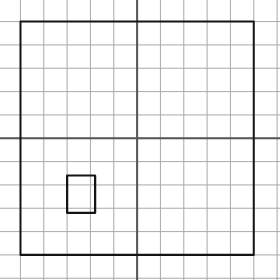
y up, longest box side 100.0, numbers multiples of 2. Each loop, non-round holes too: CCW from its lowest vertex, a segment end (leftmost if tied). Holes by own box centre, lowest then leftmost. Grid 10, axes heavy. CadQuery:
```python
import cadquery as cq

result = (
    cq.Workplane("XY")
    .moveTo(-50.0, -50.0)
    .lineTo(50.0, -50.0)
    .lineTo(50.0, 50.0)
    .lineTo(-50.0, 50.0)
    .close()
    .moveTo(-30.0, -32.0)
    .lineTo(-18.0, -32.0)
    .lineTo(-18.0, -16.0)
    .lineTo(-30.0, -16.0)
    .close()
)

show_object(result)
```